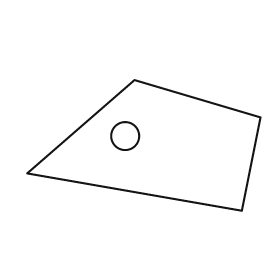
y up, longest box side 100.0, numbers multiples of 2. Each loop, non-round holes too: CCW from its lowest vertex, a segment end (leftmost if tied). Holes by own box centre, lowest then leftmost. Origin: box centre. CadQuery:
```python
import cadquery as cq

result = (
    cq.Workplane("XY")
    .moveTo(42.0, -28.0)
    .lineTo(50.0, 12.0)
    .lineTo(-4.0, 28.0)
    .lineTo(-50.0, -12.0)
    .close()
    .moveTo(-8.0, 4.0)
    .circle(6.0)
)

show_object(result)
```